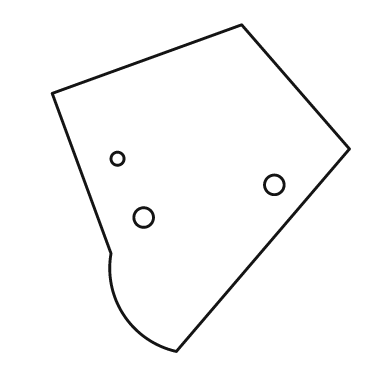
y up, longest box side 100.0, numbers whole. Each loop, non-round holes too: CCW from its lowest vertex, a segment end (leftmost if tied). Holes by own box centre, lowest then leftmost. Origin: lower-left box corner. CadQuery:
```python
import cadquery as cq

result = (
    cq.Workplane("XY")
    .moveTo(38.0, 0.0)
    .lineTo(91.0, 62.0)
    .lineTo(58.0, 100.0)
    .lineTo(0.0, 79.0)
    .lineTo(18.0, 30.0)
    .threePointArc((22.0, 11.0), (38.0, 0.0))
    .close()
    .moveTo(28.0, 41.0)
    .circle(3.0)
    .moveTo(68.0, 51.0)
    .circle(3.0)
    .moveTo(20.0, 59.0)
    .circle(2.0)
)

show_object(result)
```